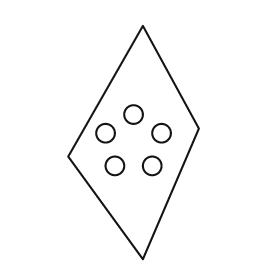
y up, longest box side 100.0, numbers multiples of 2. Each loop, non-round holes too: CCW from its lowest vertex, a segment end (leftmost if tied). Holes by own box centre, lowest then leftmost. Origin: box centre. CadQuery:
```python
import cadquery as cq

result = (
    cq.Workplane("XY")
    .moveTo(4.0, -50.0)
    .lineTo(28.0, 6.0)
    .lineTo(4.0, 50.0)
    .lineTo(-28.0, -6.0)
    .close()
    .moveTo(-8.0, -10.0)
    .circle(4.0)
    .moveTo(8.0, -10.0)
    .circle(4.0)
    .moveTo(-12.0, 4.0)
    .circle(4.0)
    .moveTo(12.0, 4.0)
    .circle(4.0)
    .moveTo(0.0, 12.0)
    .circle(4.0)
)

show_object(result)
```